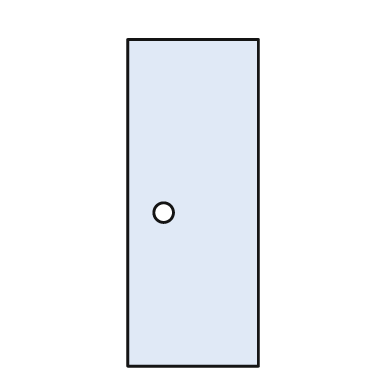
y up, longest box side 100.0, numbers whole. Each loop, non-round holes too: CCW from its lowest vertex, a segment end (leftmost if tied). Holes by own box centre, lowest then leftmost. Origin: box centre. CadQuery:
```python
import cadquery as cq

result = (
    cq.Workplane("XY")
    .moveTo(-20.0, -50.0)
    .lineTo(20.0, -50.0)
    .lineTo(20.0, 50.0)
    .lineTo(-20.0, 50.0)
    .close()
    .moveTo(-9.0, -3.0)
    .circle(3.0)
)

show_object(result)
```